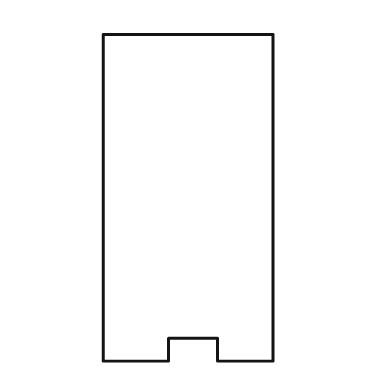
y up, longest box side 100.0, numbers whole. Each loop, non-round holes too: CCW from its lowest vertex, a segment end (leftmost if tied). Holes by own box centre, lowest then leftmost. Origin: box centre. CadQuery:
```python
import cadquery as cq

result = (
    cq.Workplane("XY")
    .moveTo(-26.0, -50.0)
    .lineTo(-6.0, -50.0)
    .lineTo(-6.0, -43.0)
    .lineTo(9.0, -43.0)
    .lineTo(9.0, -50.0)
    .lineTo(26.0, -50.0)
    .lineTo(26.0, 50.0)
    .lineTo(-26.0, 50.0)
    .close()
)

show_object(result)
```